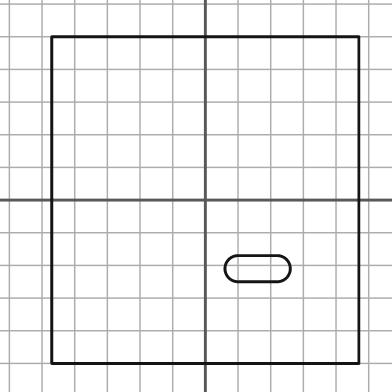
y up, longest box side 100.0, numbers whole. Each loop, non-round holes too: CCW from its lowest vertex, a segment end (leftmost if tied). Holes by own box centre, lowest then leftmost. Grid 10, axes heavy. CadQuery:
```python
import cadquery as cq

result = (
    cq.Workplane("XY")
    .moveTo(-47.0, -50.0)
    .lineTo(47.0, -50.0)
    .lineTo(47.0, 50.0)
    .lineTo(-47.0, 50.0)
    .close()
    .moveTo(10.0, -25.0)
    .lineTo(22.0, -25.0)
    .threePointArc((26.0, -21.0), (22.0, -17.0))
    .lineTo(10.0, -17.0)
    .threePointArc((6.0, -21.0), (10.0, -25.0))
    .close()
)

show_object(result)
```